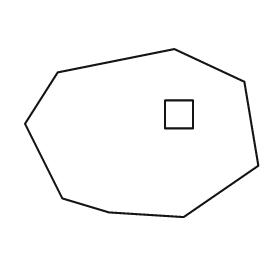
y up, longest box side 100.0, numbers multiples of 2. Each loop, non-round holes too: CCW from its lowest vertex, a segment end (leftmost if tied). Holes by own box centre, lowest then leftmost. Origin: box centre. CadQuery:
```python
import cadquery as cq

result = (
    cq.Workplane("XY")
    .moveTo(18.0, -36.0)
    .lineTo(50.0, -14.0)
    .lineTo(44.0, 22.0)
    .lineTo(14.0, 36.0)
    .lineTo(-36.0, 26.0)
    .lineTo(-50.0, 4.0)
    .lineTo(-34.0, -28.0)
    .lineTo(-14.0, -34.0)
    .close()
    .moveTo(10.0, 2.0)
    .lineTo(22.0, 2.0)
    .lineTo(22.0, 14.0)
    .lineTo(10.0, 14.0)
    .close()
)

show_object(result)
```